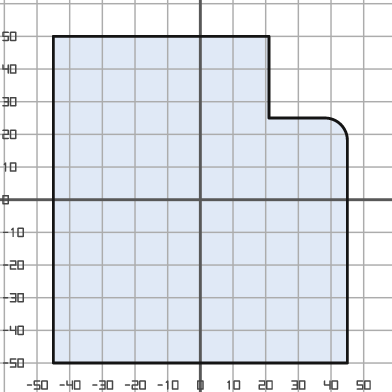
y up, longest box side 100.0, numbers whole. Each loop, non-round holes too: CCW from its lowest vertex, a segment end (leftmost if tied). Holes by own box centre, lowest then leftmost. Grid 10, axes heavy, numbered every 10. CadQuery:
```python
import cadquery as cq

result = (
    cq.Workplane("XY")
    .moveTo(-45.0, -50.0)
    .lineTo(45.0, -50.0)
    .lineTo(45.0, 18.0)
    .threePointArc((43.0, 23.0), (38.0, 25.0))
    .lineTo(21.0, 25.0)
    .lineTo(21.0, 50.0)
    .lineTo(-45.0, 50.0)
    .close()
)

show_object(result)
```